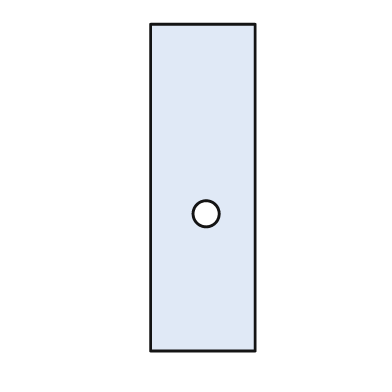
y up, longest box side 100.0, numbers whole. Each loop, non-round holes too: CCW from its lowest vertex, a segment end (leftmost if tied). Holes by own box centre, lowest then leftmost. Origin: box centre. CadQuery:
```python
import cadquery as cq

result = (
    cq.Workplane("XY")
    .moveTo(-16.0, -50.0)
    .lineTo(16.0, -50.0)
    .lineTo(16.0, 50.0)
    .lineTo(-16.0, 50.0)
    .close()
    .moveTo(1.0, -8.0)
    .circle(4.0)
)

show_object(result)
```